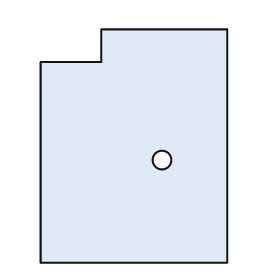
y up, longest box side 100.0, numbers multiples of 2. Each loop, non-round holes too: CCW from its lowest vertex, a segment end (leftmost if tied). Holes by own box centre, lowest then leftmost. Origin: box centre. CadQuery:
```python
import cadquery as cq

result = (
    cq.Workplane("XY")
    .moveTo(-40.0, -50.0)
    .lineTo(40.0, -50.0)
    .lineTo(40.0, 50.0)
    .lineTo(-14.0, 50.0)
    .lineTo(-14.0, 36.0)
    .lineTo(-40.0, 36.0)
    .close()
    .moveTo(12.0, -6.0)
    .circle(4.0)
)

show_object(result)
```